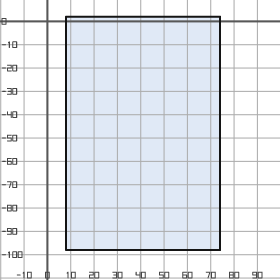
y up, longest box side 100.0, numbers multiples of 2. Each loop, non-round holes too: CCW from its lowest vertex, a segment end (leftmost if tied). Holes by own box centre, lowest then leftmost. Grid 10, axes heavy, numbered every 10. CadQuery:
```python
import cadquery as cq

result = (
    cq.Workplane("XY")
    .moveTo(8.0, -98.0)
    .lineTo(74.0, -98.0)
    .lineTo(74.0, 2.0)
    .lineTo(8.0, 2.0)
    .close()
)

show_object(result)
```